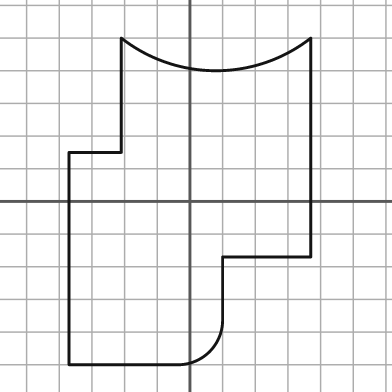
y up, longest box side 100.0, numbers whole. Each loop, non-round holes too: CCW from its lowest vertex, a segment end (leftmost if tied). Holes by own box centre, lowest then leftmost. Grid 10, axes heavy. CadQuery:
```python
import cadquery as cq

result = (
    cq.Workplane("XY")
    .moveTo(-37.0, -50.0)
    .lineTo(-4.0, -50.0)
    .threePointArc((6.0, -46.0), (10.0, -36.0))
    .lineTo(10.0, -17.0)
    .lineTo(37.0, -17.0)
    .lineTo(37.0, 50.0)
    .threePointArc((8.0, 40.0), (-21.0, 50.0))
    .lineTo(-21.0, 15.0)
    .lineTo(-37.0, 15.0)
    .close()
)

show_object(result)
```